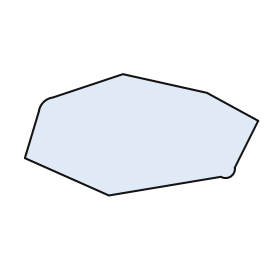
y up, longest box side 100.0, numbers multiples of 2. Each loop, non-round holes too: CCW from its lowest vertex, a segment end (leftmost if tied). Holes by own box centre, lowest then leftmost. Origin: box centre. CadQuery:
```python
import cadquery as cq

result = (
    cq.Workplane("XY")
    .moveTo(-14.0, -26.0)
    .lineTo(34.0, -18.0)
    .threePointArc((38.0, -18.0), (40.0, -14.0))
    .lineTo(50.0, 6.0)
    .lineTo(28.0, 18.0)
    .lineTo(-8.0, 26.0)
    .lineTo(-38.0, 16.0)
    .threePointArc((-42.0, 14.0), (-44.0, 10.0))
    .lineTo(-50.0, -10.0)
    .close()
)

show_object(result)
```